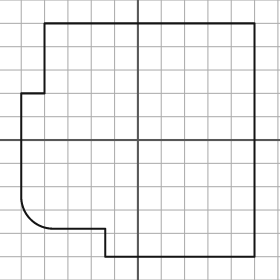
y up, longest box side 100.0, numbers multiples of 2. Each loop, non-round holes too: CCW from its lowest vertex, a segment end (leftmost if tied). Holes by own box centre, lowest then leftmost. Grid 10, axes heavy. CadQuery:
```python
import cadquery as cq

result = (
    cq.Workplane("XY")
    .moveTo(-14.0, -50.0)
    .lineTo(50.0, -50.0)
    .lineTo(50.0, 50.0)
    .lineTo(-40.0, 50.0)
    .lineTo(-40.0, 20.0)
    .lineTo(-50.0, 20.0)
    .lineTo(-50.0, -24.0)
    .threePointArc((-46.0, -34.0), (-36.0, -38.0))
    .lineTo(-14.0, -38.0)
    .close()
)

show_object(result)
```